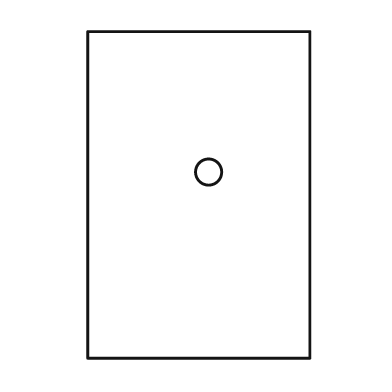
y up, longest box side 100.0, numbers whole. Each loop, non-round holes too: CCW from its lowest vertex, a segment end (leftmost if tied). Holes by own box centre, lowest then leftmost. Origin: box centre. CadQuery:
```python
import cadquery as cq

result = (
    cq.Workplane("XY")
    .moveTo(-34.0, -50.0)
    .lineTo(34.0, -50.0)
    .lineTo(34.0, 50.0)
    .lineTo(-34.0, 50.0)
    .close()
    .moveTo(3.0, 7.0)
    .circle(4.0)
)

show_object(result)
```